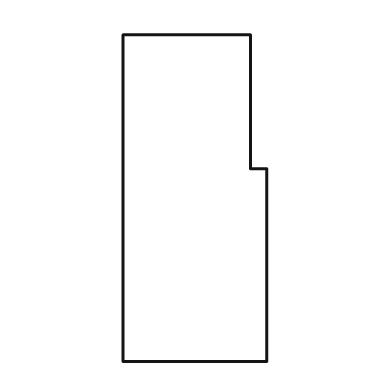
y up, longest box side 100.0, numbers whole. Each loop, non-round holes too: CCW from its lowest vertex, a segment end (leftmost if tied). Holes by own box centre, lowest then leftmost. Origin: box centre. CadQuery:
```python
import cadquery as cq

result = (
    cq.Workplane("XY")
    .moveTo(-22.0, -50.0)
    .lineTo(22.0, -50.0)
    .lineTo(22.0, 9.0)
    .lineTo(17.0, 9.0)
    .lineTo(17.0, 50.0)
    .lineTo(-22.0, 50.0)
    .close()
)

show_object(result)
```